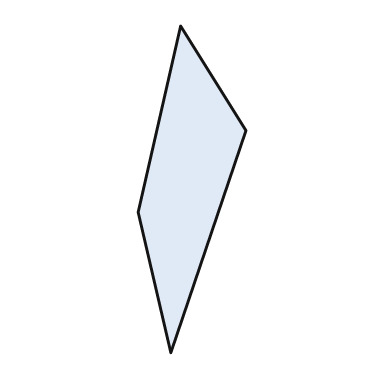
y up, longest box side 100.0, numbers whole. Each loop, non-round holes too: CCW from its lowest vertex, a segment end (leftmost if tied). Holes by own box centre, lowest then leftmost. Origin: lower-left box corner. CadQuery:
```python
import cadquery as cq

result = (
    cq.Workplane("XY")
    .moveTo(10.0, 0.0)
    .lineTo(33.0, 68.0)
    .lineTo(13.0, 100.0)
    .lineTo(0.0, 43.0)
    .close()
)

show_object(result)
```